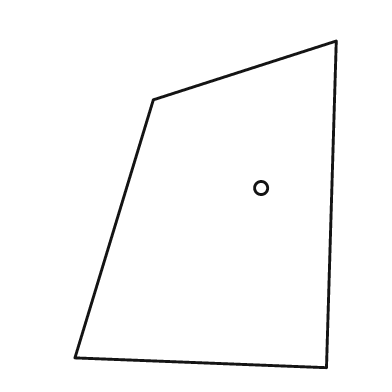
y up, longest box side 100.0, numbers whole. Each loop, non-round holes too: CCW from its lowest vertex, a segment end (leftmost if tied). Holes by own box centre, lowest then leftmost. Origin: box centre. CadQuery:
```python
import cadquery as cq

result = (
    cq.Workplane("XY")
    .moveTo(37.0, -50.0)
    .lineTo(40.0, 50.0)
    .lineTo(-16.0, 32.0)
    .lineTo(-40.0, -47.0)
    .close()
    .moveTo(17.0, 5.0)
    .circle(2.0)
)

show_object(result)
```